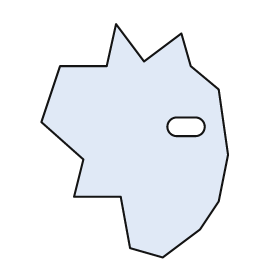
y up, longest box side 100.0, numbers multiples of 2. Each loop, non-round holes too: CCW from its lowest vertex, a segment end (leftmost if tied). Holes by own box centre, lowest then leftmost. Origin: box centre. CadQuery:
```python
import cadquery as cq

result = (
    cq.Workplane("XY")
    .moveTo(12.0, -50.0)
    .lineTo(28.0, -38.0)
    .lineTo(36.0, -26.0)
    .lineTo(40.0, -6.0)
    .lineTo(36.0, 22.0)
    .lineTo(24.0, 32.0)
    .lineTo(20.0, 46.0)
    .lineTo(4.0, 34.0)
    .lineTo(-8.0, 50.0)
    .lineTo(-12.0, 32.0)
    .lineTo(-32.0, 32.0)
    .lineTo(-40.0, 8.0)
    .lineTo(-22.0, -8.0)
    .lineTo(-26.0, -24.0)
    .lineTo(-6.0, -24.0)
    .lineTo(-2.0, -46.0)
    .close()
    .moveTo(18.0, 2.0)
    .lineTo(26.0, 2.0)
    .threePointArc((30.0, 6.0), (26.0, 10.0))
    .lineTo(18.0, 10.0)
    .threePointArc((14.0, 6.0), (18.0, 2.0))
    .close()
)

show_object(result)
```